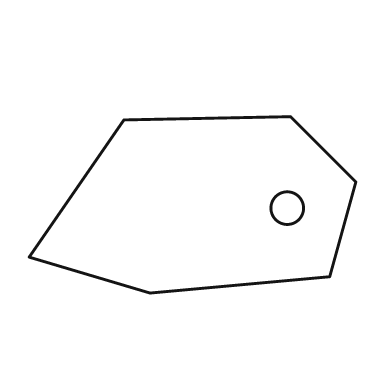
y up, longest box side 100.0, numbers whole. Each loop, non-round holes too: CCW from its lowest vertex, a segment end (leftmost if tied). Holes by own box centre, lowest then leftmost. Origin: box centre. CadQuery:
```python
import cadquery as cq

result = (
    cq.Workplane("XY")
    .moveTo(-13.0, -27.0)
    .lineTo(42.0, -22.0)
    .lineTo(50.0, 7.0)
    .lineTo(30.0, 27.0)
    .lineTo(-21.0, 26.0)
    .lineTo(-50.0, -16.0)
    .close()
    .moveTo(29.0, -1.0)
    .circle(5.0)
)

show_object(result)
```